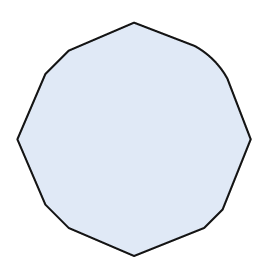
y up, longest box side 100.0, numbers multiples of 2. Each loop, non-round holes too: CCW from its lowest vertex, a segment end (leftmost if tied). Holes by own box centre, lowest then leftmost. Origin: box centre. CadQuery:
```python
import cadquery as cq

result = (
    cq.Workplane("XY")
    .moveTo(0.0, -50.0)
    .lineTo(30.0, -38.0)
    .lineTo(38.0, -30.0)
    .lineTo(50.0, 0.0)
    .lineTo(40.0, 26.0)
    .threePointArc((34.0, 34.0), (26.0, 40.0))
    .lineTo(0.0, 50.0)
    .lineTo(-28.0, 38.0)
    .lineTo(-38.0, 28.0)
    .lineTo(-50.0, 0.0)
    .lineTo(-38.0, -28.0)
    .lineTo(-28.0, -38.0)
    .close()
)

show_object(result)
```